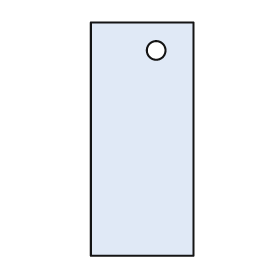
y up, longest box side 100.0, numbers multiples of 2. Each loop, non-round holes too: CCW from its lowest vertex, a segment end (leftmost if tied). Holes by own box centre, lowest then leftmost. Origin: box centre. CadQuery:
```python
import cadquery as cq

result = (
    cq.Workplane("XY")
    .moveTo(-22.0, -50.0)
    .lineTo(22.0, -50.0)
    .lineTo(22.0, 50.0)
    .lineTo(-22.0, 50.0)
    .close()
    .moveTo(6.0, 38.0)
    .circle(4.0)
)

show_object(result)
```